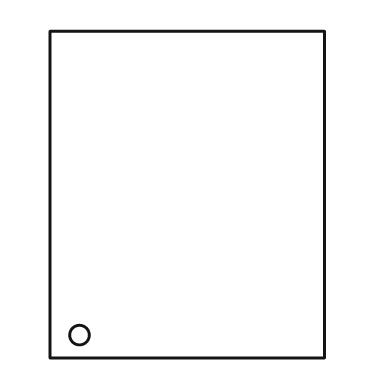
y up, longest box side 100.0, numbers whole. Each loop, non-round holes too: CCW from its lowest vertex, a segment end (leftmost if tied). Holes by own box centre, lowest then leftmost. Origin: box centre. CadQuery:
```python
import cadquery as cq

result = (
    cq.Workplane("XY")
    .moveTo(-42.0, -50.0)
    .lineTo(42.0, -50.0)
    .lineTo(42.0, 50.0)
    .lineTo(-42.0, 50.0)
    .close()
    .moveTo(-33.0, -43.0)
    .circle(3.0)
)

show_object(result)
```